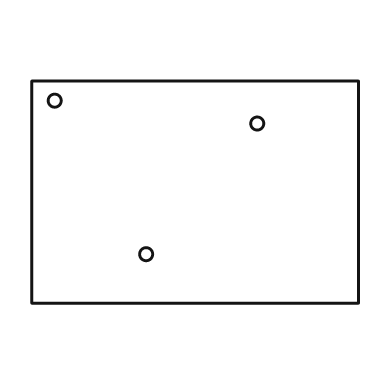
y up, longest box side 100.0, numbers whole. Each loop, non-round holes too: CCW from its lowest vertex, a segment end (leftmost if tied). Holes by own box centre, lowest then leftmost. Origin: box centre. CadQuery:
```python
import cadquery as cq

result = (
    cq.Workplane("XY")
    .moveTo(-50.0, -34.0)
    .lineTo(50.0, -34.0)
    .lineTo(50.0, 34.0)
    .lineTo(-50.0, 34.0)
    .close()
    .moveTo(-15.0, -19.0)
    .circle(2.0)
    .moveTo(19.0, 21.0)
    .circle(2.0)
    .moveTo(-43.0, 28.0)
    .circle(2.0)
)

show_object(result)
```